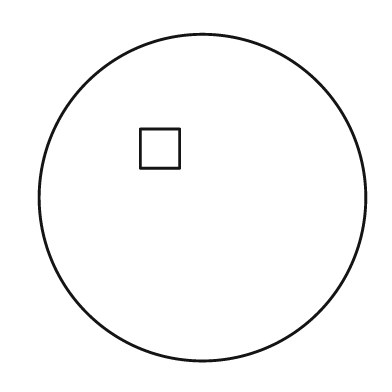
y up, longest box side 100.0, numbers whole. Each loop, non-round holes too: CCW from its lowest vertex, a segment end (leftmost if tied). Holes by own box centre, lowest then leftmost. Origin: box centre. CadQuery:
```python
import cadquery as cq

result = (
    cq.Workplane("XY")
    .moveTo(0.0, 0.0)
    .circle(50.0)
    .moveTo(-19.0, 9.0)
    .lineTo(-7.0, 9.0)
    .lineTo(-7.0, 21.0)
    .lineTo(-19.0, 21.0)
    .close()
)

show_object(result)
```